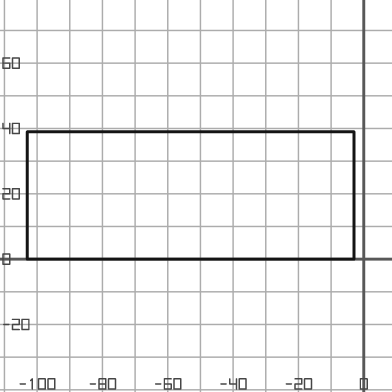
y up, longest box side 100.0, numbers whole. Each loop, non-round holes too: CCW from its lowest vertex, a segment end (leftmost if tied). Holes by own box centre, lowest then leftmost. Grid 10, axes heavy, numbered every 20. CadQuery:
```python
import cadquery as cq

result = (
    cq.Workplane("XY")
    .moveTo(-103.0, 0.0)
    .lineTo(-3.0, 0.0)
    .lineTo(-3.0, 39.0)
    .lineTo(-103.0, 39.0)
    .close()
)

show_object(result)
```